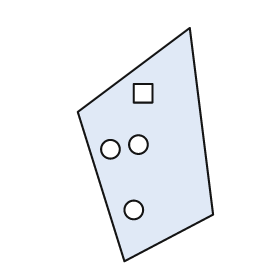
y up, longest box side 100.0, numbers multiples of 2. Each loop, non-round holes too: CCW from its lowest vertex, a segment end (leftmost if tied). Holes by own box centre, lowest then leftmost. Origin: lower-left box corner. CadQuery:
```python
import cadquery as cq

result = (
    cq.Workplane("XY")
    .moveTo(20.0, 0.0)
    .lineTo(58.0, 20.0)
    .lineTo(48.0, 100.0)
    .lineTo(0.0, 64.0)
    .close()
    .moveTo(24.0, 22.0)
    .circle(4.0)
    .moveTo(14.0, 48.0)
    .circle(4.0)
    .moveTo(26.0, 50.0)
    .circle(4.0)
    .moveTo(24.0, 68.0)
    .lineTo(32.0, 68.0)
    .lineTo(32.0, 76.0)
    .lineTo(24.0, 76.0)
    .close()
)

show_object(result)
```